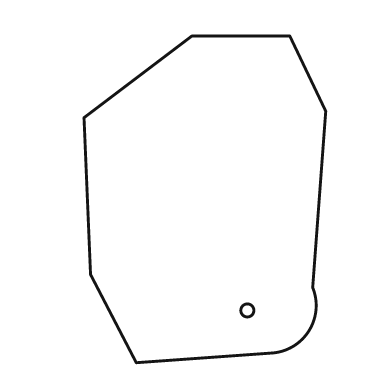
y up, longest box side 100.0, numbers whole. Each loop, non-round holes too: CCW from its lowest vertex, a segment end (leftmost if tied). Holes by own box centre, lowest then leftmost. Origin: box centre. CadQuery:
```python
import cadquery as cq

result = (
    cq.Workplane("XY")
    .moveTo(-21.0, -50.0)
    .lineTo(21.0, -47.0)
    .threePointArc((32.0, -40.0), (33.0, -27.0))
    .lineTo(37.0, 27.0)
    .lineTo(26.0, 50.0)
    .lineTo(-4.0, 50.0)
    .lineTo(-37.0, 25.0)
    .lineTo(-35.0, -23.0)
    .close()
    .moveTo(13.0, -34.0)
    .circle(2.0)
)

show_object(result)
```